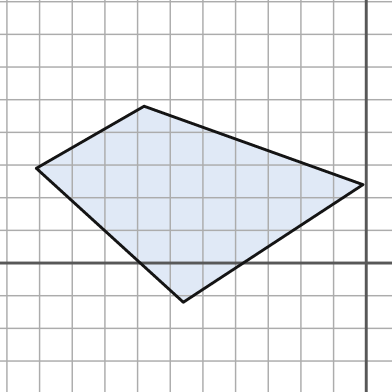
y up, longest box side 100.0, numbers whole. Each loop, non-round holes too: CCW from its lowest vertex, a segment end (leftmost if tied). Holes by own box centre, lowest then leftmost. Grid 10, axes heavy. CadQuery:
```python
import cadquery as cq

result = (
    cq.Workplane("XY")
    .moveTo(-56.0, -12.0)
    .lineTo(-1.0, 24.0)
    .lineTo(-68.0, 48.0)
    .lineTo(-101.0, 29.0)
    .close()
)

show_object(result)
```